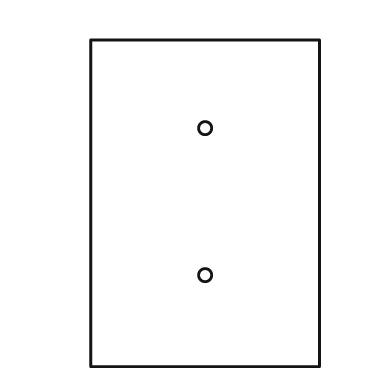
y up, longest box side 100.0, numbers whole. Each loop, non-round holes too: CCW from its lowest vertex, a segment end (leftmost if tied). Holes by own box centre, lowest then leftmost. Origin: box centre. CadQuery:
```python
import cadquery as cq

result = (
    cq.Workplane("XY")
    .moveTo(-35.0, -50.0)
    .lineTo(35.0, -50.0)
    .lineTo(35.0, 50.0)
    .lineTo(-35.0, 50.0)
    .close()
    .moveTo(0.0, -22.0)
    .circle(2.0)
    .moveTo(0.0, 23.0)
    .circle(2.0)
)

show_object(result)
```